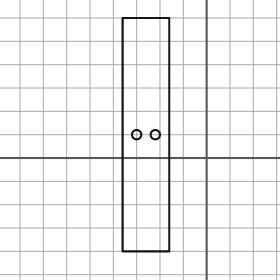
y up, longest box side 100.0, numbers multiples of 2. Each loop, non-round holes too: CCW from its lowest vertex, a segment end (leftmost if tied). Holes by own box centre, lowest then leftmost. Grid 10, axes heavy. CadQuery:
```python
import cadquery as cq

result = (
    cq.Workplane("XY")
    .moveTo(-36.0, -40.0)
    .lineTo(-16.0, -40.0)
    .lineTo(-16.0, 60.0)
    .lineTo(-36.0, 60.0)
    .close()
    .moveTo(-30.0, 10.0)
    .circle(2.0)
    .moveTo(-22.0, 10.0)
    .circle(2.0)
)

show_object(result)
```